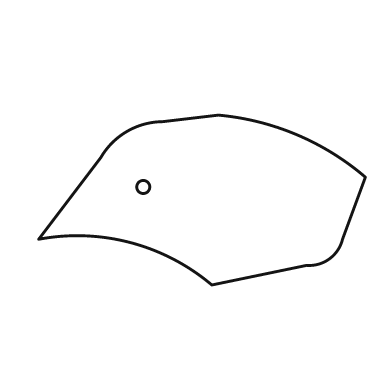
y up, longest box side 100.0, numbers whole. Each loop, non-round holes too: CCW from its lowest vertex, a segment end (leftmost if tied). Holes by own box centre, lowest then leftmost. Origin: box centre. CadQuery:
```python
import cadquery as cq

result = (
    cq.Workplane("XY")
    .moveTo(3.0, -26.0)
    .lineTo(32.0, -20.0)
    .threePointArc((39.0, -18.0), (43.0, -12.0))
    .lineTo(50.0, 7.0)
    .threePointArc((29.0, 20.0), (5.0, 26.0))
    .lineTo(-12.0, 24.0)
    .threePointArc((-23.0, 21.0), (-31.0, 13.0))
    .lineTo(-50.0, -12.0)
    .threePointArc((-22.0, -13.0), (3.0, -26.0))
    .close()
    .moveTo(-18.0, 4.0)
    .circle(2.0)
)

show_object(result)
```